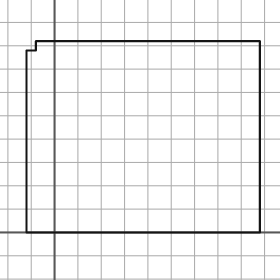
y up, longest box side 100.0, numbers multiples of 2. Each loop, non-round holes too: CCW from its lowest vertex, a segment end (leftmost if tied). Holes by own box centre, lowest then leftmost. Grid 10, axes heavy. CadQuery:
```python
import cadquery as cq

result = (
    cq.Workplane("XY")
    .moveTo(-12.0, 0.0)
    .lineTo(88.0, 0.0)
    .lineTo(88.0, 82.0)
    .lineTo(-8.0, 82.0)
    .lineTo(-8.0, 78.0)
    .lineTo(-12.0, 78.0)
    .close()
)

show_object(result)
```